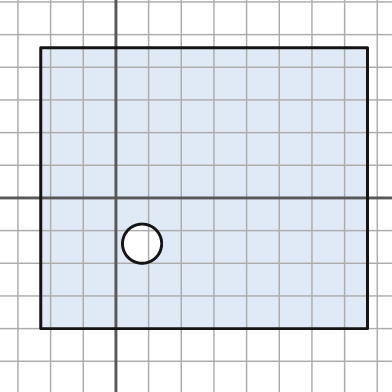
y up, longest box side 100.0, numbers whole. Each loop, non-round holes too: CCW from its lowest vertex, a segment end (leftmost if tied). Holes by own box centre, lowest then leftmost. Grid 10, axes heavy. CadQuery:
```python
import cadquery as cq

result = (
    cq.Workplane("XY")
    .moveTo(-23.0, -40.0)
    .lineTo(77.0, -40.0)
    .lineTo(77.0, 46.0)
    .lineTo(-23.0, 46.0)
    .close()
    .moveTo(8.0, -14.0)
    .circle(6.0)
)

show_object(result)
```